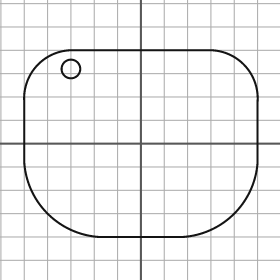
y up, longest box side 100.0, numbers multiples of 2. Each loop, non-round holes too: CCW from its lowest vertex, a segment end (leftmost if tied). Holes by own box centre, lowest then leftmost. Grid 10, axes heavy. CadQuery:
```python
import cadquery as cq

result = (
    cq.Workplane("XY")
    .moveTo(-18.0, -40.0)
    .lineTo(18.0, -40.0)
    .threePointArc((40.0, -30.0), (50.0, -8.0))
    .lineTo(50.0, 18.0)
    .threePointArc((44.0, 34.0), (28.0, 40.0))
    .lineTo(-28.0, 40.0)
    .threePointArc((-44.0, 34.0), (-50.0, 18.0))
    .lineTo(-50.0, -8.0)
    .threePointArc((-40.0, -30.0), (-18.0, -40.0))
    .close()
    .moveTo(-30.0, 32.0)
    .circle(4.0)
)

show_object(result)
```